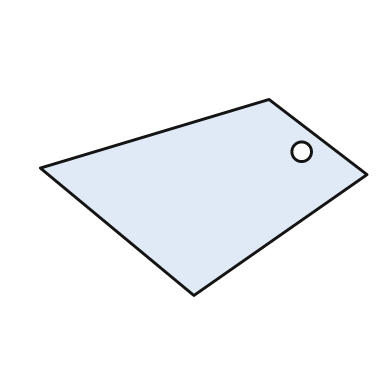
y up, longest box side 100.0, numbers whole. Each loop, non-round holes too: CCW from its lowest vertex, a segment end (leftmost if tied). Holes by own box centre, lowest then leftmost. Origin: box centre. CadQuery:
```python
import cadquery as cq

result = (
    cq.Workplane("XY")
    .moveTo(-3.0, -30.0)
    .lineTo(50.0, 7.0)
    .lineTo(20.0, 30.0)
    .lineTo(-50.0, 9.0)
    .close()
    .moveTo(30.0, 14.0)
    .circle(3.0)
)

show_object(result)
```